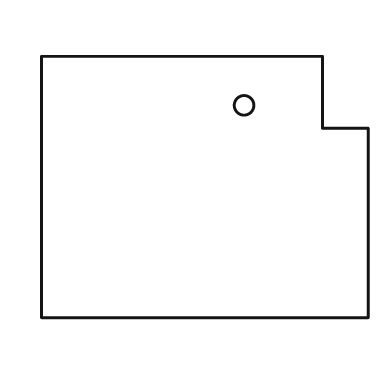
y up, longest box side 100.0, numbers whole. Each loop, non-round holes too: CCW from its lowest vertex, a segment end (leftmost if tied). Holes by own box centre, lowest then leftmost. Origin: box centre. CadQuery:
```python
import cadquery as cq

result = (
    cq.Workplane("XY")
    .moveTo(-50.0, -40.0)
    .lineTo(50.0, -40.0)
    .lineTo(50.0, 18.0)
    .lineTo(36.0, 18.0)
    .lineTo(36.0, 40.0)
    .lineTo(-50.0, 40.0)
    .close()
    .moveTo(12.0, 25.0)
    .circle(3.0)
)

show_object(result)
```